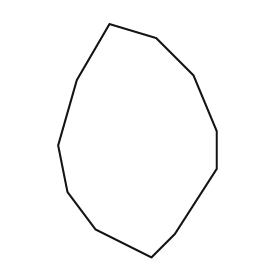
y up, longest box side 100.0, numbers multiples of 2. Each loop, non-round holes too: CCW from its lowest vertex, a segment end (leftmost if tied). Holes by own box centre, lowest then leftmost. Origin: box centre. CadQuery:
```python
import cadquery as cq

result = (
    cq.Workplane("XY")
    .moveTo(6.0, -50.0)
    .lineTo(16.0, -40.0)
    .lineTo(34.0, -12.0)
    .lineTo(34.0, 4.0)
    .lineTo(24.0, 28.0)
    .lineTo(8.0, 44.0)
    .lineTo(-12.0, 50.0)
    .lineTo(-26.0, 26.0)
    .lineTo(-34.0, -2.0)
    .lineTo(-30.0, -22.0)
    .lineTo(-18.0, -38.0)
    .close()
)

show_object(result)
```